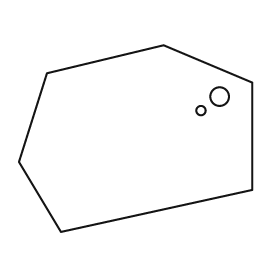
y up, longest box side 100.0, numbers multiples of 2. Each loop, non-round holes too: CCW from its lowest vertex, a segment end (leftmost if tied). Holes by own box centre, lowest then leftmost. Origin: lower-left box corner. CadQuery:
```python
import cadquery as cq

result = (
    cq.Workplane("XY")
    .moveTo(18.0, 0.0)
    .lineTo(100.0, 18.0)
    .lineTo(100.0, 64.0)
    .lineTo(62.0, 80.0)
    .lineTo(12.0, 68.0)
    .lineTo(0.0, 30.0)
    .close()
    .moveTo(78.0, 52.0)
    .circle(2.0)
    .moveTo(86.0, 58.0)
    .circle(4.0)
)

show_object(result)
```